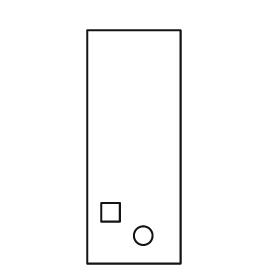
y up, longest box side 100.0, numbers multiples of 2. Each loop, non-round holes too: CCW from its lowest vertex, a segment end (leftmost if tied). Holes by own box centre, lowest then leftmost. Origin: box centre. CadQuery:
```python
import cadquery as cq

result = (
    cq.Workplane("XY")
    .moveTo(-20.0, -50.0)
    .lineTo(20.0, -50.0)
    .lineTo(20.0, 50.0)
    .lineTo(-20.0, 50.0)
    .close()
    .moveTo(4.0, -38.0)
    .circle(4.0)
    .moveTo(-14.0, -32.0)
    .lineTo(-6.0, -32.0)
    .lineTo(-6.0, -24.0)
    .lineTo(-14.0, -24.0)
    .close()
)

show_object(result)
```